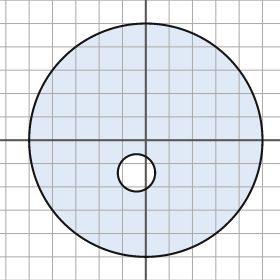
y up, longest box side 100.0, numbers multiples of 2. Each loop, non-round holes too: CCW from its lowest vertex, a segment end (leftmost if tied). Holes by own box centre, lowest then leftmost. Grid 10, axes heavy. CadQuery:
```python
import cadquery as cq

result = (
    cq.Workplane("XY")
    .moveTo(0.0, 0.0)
    .circle(50.0)
    .moveTo(-4.0, -14.0)
    .circle(8.0)
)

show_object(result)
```